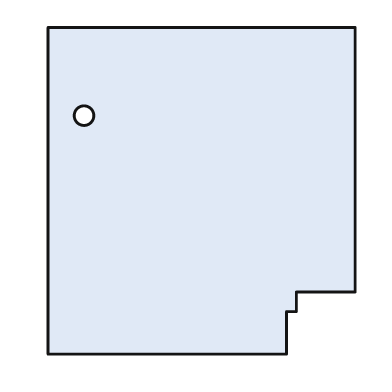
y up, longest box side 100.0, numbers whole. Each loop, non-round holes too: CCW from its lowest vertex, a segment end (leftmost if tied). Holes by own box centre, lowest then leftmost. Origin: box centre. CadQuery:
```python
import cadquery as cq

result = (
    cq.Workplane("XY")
    .moveTo(-47.0, -50.0)
    .lineTo(26.0, -50.0)
    .lineTo(26.0, -37.0)
    .lineTo(29.0, -37.0)
    .lineTo(29.0, -31.0)
    .lineTo(47.0, -31.0)
    .lineTo(47.0, 50.0)
    .lineTo(-47.0, 50.0)
    .close()
    .moveTo(-36.0, 23.0)
    .circle(3.0)
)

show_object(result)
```